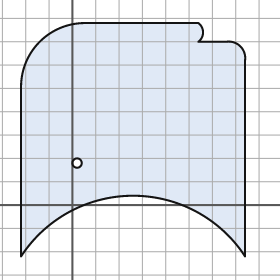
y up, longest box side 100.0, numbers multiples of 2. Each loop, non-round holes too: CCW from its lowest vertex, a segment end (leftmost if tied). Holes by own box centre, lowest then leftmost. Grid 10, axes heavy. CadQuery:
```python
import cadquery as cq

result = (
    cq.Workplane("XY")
    .moveTo(-22.0, -22.0)
    .threePointArc((26.0, 4.0), (74.0, -22.0))
    .lineTo(74.0, 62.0)
    .threePointArc((72.0, 68.0), (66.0, 70.0))
    .lineTo(54.0, 70.0)
    .threePointArc((56.0, 74.0), (54.0, 78.0))
    .lineTo(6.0, 78.0)
    .threePointArc((-14.0, 70.0), (-22.0, 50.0))
    .close()
    .moveTo(2.0, 18.0)
    .circle(2.0)
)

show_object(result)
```